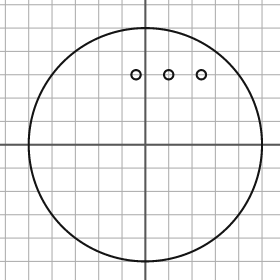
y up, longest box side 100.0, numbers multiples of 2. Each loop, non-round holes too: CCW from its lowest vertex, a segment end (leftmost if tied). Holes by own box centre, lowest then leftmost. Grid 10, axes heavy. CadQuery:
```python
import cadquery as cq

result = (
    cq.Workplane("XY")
    .moveTo(0.0, 0.0)
    .circle(50.0)
    .moveTo(-4.0, 30.0)
    .circle(2.0)
    .moveTo(10.0, 30.0)
    .circle(2.0)
    .moveTo(24.0, 30.0)
    .circle(2.0)
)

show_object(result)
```